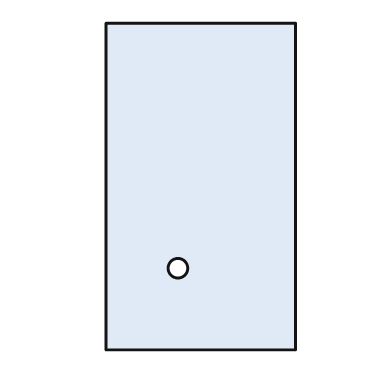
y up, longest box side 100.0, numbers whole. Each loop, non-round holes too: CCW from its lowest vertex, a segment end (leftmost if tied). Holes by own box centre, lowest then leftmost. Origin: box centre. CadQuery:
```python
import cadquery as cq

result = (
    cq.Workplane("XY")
    .moveTo(-29.0, -50.0)
    .lineTo(29.0, -50.0)
    .lineTo(29.0, 50.0)
    .lineTo(-29.0, 50.0)
    .close()
    .moveTo(-7.0, -25.0)
    .circle(3.0)
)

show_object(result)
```